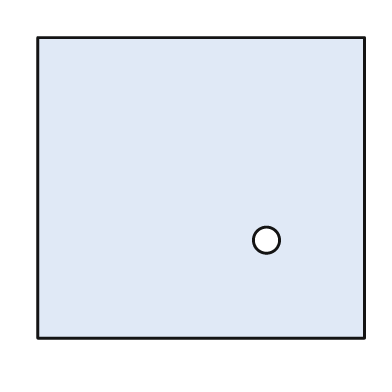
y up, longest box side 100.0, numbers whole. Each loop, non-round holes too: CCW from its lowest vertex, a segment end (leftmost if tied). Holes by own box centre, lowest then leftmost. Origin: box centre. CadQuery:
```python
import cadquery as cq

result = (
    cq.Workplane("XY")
    .moveTo(-50.0, -46.0)
    .lineTo(50.0, -46.0)
    .lineTo(50.0, 46.0)
    .lineTo(-50.0, 46.0)
    .close()
    .moveTo(20.0, -16.0)
    .circle(4.0)
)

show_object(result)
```